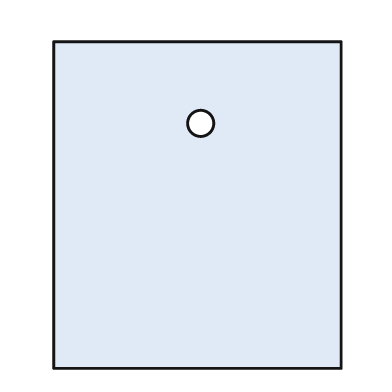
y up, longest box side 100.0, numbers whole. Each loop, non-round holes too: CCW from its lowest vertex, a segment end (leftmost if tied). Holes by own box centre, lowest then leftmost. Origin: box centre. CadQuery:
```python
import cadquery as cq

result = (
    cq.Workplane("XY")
    .moveTo(-44.0, -50.0)
    .lineTo(44.0, -50.0)
    .lineTo(44.0, 50.0)
    .lineTo(-44.0, 50.0)
    .close()
    .moveTo(1.0, 25.0)
    .circle(4.0)
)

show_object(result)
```